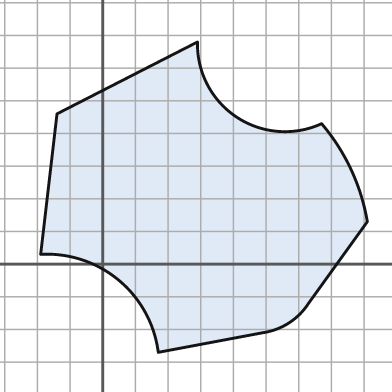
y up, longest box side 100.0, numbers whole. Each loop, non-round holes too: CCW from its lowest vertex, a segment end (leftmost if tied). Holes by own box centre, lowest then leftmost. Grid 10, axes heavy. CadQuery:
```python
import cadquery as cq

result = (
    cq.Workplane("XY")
    .moveTo(17.0, -27.0)
    .lineTo(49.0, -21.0)
    .threePointArc((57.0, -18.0), (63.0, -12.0))
    .lineTo(81.0, 13.0)
    .threePointArc((76.0, 29.0), (67.0, 43.0))
    .threePointArc((41.0, 45.0), (29.0, 68.0))
    .lineTo(-14.0, 46.0)
    .lineTo(-19.0, 3.0)
    .threePointArc((5.0, -5.0), (17.0, -27.0))
    .close()
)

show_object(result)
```